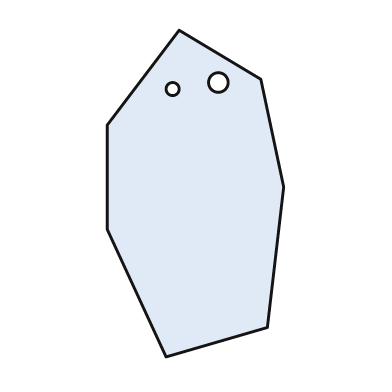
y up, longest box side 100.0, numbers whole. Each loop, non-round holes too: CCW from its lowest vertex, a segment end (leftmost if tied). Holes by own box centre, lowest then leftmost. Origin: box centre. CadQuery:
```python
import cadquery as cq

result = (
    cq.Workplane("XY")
    .moveTo(-9.0, -50.0)
    .lineTo(22.0, -41.0)
    .lineTo(27.0, 2.0)
    .lineTo(20.0, 35.0)
    .lineTo(-5.0, 50.0)
    .lineTo(-27.0, 21.0)
    .lineTo(-27.0, -11.0)
    .close()
    .moveTo(-7.0, 32.0)
    .circle(2.0)
    .moveTo(7.0, 34.0)
    .circle(3.0)
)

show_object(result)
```